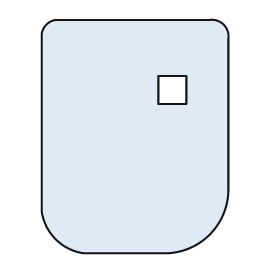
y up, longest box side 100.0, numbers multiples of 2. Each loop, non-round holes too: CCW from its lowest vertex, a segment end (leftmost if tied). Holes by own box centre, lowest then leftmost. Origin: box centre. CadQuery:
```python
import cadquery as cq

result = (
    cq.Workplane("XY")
    .moveTo(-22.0, -50.0)
    .lineTo(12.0, -50.0)
    .threePointArc((32.0, -42.0), (40.0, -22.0))
    .lineTo(40.0, 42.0)
    .threePointArc((38.0, 48.0), (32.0, 50.0))
    .lineTo(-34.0, 50.0)
    .threePointArc((-38.0, 48.0), (-40.0, 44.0))
    .lineTo(-40.0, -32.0)
    .threePointArc((-34.0, -44.0), (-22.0, -50.0))
    .close()
    .moveTo(10.0, 14.0)
    .lineTo(22.0, 14.0)
    .lineTo(22.0, 26.0)
    .lineTo(10.0, 26.0)
    .close()
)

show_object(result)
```